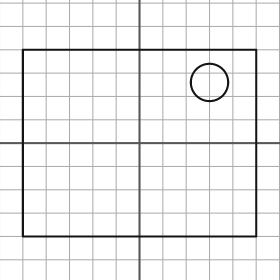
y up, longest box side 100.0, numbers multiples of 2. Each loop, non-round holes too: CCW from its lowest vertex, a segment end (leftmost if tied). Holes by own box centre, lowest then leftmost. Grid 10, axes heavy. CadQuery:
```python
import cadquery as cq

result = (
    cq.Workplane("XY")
    .moveTo(-50.0, -40.0)
    .lineTo(50.0, -40.0)
    .lineTo(50.0, 40.0)
    .lineTo(-50.0, 40.0)
    .close()
    .moveTo(30.0, 26.0)
    .circle(8.0)
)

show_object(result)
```